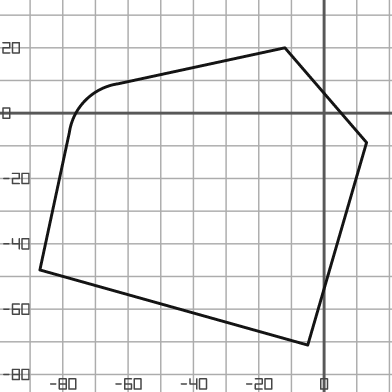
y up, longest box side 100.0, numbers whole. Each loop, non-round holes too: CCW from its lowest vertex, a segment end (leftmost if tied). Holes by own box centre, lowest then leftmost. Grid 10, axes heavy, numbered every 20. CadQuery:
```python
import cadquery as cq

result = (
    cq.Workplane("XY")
    .moveTo(-5.0, -71.0)
    .lineTo(13.0, -9.0)
    .lineTo(-12.0, 20.0)
    .lineTo(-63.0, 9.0)
    .threePointArc((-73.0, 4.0), (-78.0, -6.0))
    .lineTo(-87.0, -48.0)
    .close()
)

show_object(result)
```